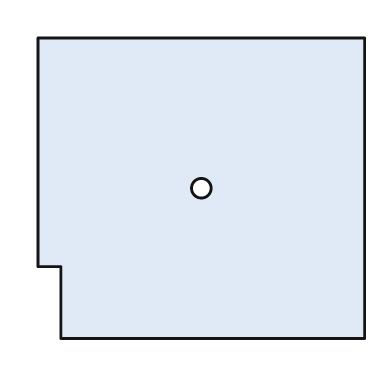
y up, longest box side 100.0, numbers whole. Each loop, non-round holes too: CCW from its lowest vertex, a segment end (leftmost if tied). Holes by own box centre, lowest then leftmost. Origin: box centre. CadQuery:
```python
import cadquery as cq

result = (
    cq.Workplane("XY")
    .moveTo(-43.0, -46.0)
    .lineTo(50.0, -46.0)
    .lineTo(50.0, 46.0)
    .lineTo(-50.0, 46.0)
    .lineTo(-50.0, -24.0)
    .lineTo(-43.0, -24.0)
    .close()
    .moveTo(0.0, 0.0)
    .circle(3.0)
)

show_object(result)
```